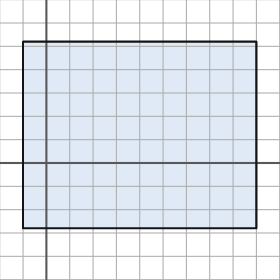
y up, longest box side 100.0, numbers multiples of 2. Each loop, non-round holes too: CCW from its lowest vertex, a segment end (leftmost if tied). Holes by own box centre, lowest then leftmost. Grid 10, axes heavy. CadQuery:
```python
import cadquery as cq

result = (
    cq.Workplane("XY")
    .moveTo(-10.0, -28.0)
    .lineTo(90.0, -28.0)
    .lineTo(90.0, 52.0)
    .lineTo(-10.0, 52.0)
    .close()
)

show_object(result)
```